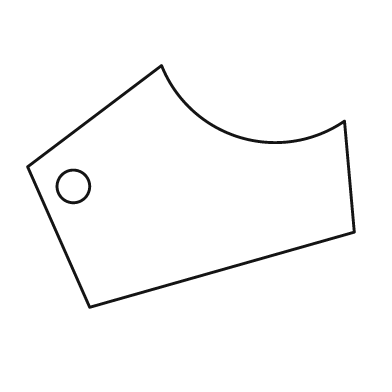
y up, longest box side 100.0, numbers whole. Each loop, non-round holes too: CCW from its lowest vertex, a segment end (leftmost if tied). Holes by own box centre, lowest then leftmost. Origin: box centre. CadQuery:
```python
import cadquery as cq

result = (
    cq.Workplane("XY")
    .moveTo(-31.0, -37.0)
    .lineTo(50.0, -14.0)
    .lineTo(47.0, 20.0)
    .threePointArc((15.0, 15.0), (-9.0, 37.0))
    .lineTo(-50.0, 6.0)
    .close()
    .moveTo(-36.0, 0.0)
    .circle(5.0)
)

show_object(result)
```